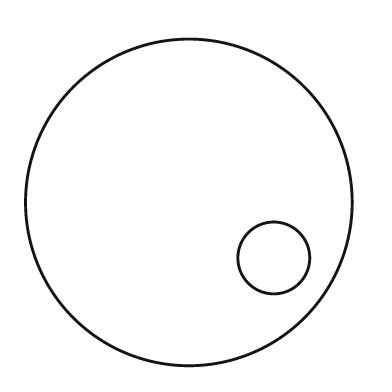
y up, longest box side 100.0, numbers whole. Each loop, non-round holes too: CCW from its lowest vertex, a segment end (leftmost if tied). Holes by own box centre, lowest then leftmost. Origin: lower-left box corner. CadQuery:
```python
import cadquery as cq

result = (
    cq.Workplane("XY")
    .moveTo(50.0, 50.0)
    .circle(50.0)
    .moveTo(76.0, 33.0)
    .circle(11.0)
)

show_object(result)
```